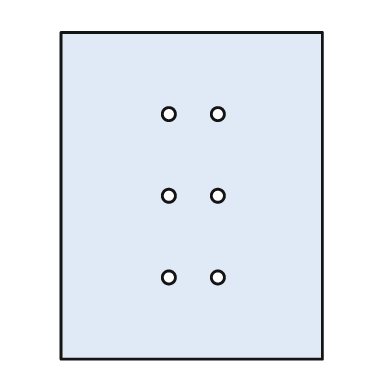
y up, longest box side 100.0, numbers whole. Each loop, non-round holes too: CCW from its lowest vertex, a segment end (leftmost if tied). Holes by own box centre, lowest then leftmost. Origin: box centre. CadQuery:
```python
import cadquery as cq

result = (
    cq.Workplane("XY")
    .moveTo(-40.0, -50.0)
    .lineTo(40.0, -50.0)
    .lineTo(40.0, 50.0)
    .lineTo(-40.0, 50.0)
    .close()
    .moveTo(-7.0, -25.0)
    .circle(2.0)
    .moveTo(8.0, -25.0)
    .circle(2.0)
    .moveTo(-7.0, 0.0)
    .circle(2.0)
    .moveTo(8.0, 0.0)
    .circle(2.0)
    .moveTo(-7.0, 25.0)
    .circle(2.0)
    .moveTo(8.0, 25.0)
    .circle(2.0)
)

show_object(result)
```